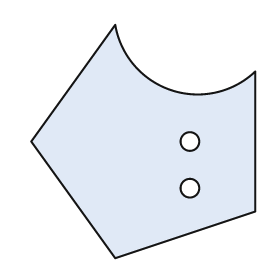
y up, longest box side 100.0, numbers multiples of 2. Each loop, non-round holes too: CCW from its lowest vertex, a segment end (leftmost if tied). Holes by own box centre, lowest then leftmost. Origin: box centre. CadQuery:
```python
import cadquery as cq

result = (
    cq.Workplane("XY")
    .moveTo(-12.0, -50.0)
    .lineTo(48.0, -30.0)
    .lineTo(48.0, 30.0)
    .threePointArc((12.0, 22.0), (-12.0, 50.0))
    .lineTo(-48.0, 0.0)
    .close()
    .moveTo(20.0, -20.0)
    .circle(4.0)
    .moveTo(20.0, 0.0)
    .circle(4.0)
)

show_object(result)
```